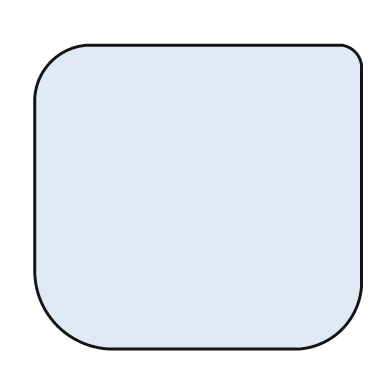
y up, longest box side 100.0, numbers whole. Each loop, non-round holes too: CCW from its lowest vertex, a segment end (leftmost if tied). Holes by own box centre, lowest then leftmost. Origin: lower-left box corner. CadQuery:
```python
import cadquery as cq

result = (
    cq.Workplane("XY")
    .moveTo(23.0, 0.0)
    .lineTo(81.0, 0.0)
    .threePointArc((94.0, 6.0), (100.0, 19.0))
    .lineTo(100.0, 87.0)
    .threePointArc((98.0, 91.0), (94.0, 93.0))
    .lineTo(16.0, 93.0)
    .threePointArc((5.0, 88.0), (0.0, 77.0))
    .lineTo(0.0, 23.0)
    .threePointArc((7.0, 7.0), (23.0, 0.0))
    .close()
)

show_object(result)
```